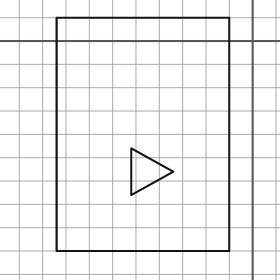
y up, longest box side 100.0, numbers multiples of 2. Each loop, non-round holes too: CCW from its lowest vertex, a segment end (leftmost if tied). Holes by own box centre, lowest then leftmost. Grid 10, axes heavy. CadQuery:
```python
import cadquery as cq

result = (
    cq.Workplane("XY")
    .moveTo(-84.0, -90.0)
    .lineTo(-10.0, -90.0)
    .lineTo(-10.0, 10.0)
    .lineTo(-84.0, 10.0)
    .close()
    .moveTo(-52.0, -66.0)
    .lineTo(-34.0, -56.0)
    .lineTo(-52.0, -46.0)
    .close()
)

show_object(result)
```